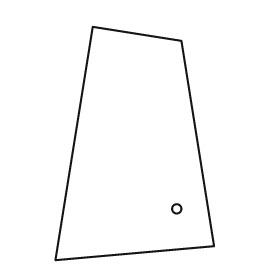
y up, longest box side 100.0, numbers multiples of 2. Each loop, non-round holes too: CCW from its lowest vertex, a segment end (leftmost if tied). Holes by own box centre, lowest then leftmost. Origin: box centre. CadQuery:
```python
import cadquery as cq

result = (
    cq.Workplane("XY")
    .moveTo(-34.0, -50.0)
    .lineTo(34.0, -44.0)
    .lineTo(20.0, 44.0)
    .lineTo(-18.0, 50.0)
    .close()
    .moveTo(18.0, -28.0)
    .circle(2.0)
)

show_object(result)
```